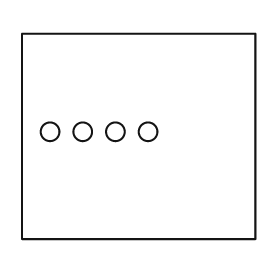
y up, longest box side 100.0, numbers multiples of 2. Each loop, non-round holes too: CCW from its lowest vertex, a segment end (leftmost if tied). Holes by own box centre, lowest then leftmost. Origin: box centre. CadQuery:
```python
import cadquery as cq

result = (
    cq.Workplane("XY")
    .moveTo(-50.0, -44.0)
    .lineTo(50.0, -44.0)
    .lineTo(50.0, 44.0)
    .lineTo(-50.0, 44.0)
    .close()
    .moveTo(-38.0, 2.0)
    .circle(4.0)
    .moveTo(-24.0, 2.0)
    .circle(4.0)
    .moveTo(-10.0, 2.0)
    .circle(4.0)
    .moveTo(4.0, 2.0)
    .circle(4.0)
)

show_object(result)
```